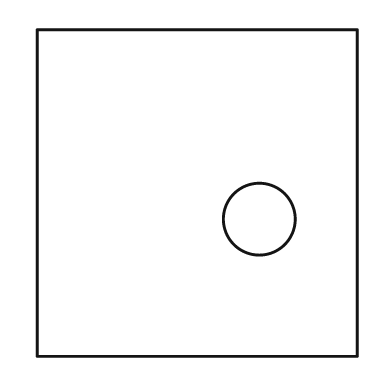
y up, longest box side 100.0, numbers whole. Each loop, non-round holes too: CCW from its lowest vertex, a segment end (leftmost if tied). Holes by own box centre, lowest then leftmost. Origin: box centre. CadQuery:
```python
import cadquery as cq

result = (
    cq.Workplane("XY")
    .moveTo(-49.0, -50.0)
    .lineTo(49.0, -50.0)
    .lineTo(49.0, 50.0)
    .lineTo(-49.0, 50.0)
    .close()
    .moveTo(19.0, -8.0)
    .circle(11.0)
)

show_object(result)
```